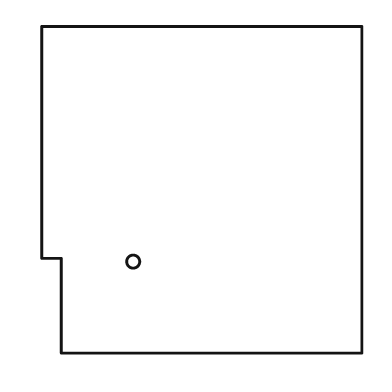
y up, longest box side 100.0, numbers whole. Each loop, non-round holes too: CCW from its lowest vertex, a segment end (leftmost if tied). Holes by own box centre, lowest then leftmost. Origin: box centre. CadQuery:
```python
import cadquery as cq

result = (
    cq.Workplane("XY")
    .moveTo(-43.0, -50.0)
    .lineTo(49.0, -50.0)
    .lineTo(49.0, 50.0)
    .lineTo(-49.0, 50.0)
    .lineTo(-49.0, -21.0)
    .lineTo(-43.0, -21.0)
    .close()
    .moveTo(-21.0, -22.0)
    .circle(2.0)
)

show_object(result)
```